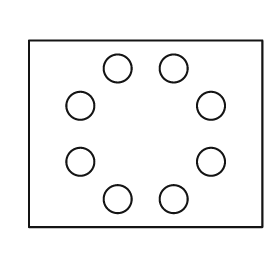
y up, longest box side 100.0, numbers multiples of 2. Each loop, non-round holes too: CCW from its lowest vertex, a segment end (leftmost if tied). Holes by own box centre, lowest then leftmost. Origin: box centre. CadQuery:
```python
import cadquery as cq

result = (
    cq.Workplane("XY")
    .moveTo(-50.0, -40.0)
    .lineTo(50.0, -40.0)
    .lineTo(50.0, 40.0)
    .lineTo(-50.0, 40.0)
    .close()
    .moveTo(-12.0, -28.0)
    .circle(6.0)
    .moveTo(12.0, -28.0)
    .circle(6.0)
    .moveTo(-28.0, -12.0)
    .circle(6.0)
    .moveTo(28.0, -12.0)
    .circle(6.0)
    .moveTo(-28.0, 12.0)
    .circle(6.0)
    .moveTo(28.0, 12.0)
    .circle(6.0)
    .moveTo(-12.0, 28.0)
    .circle(6.0)
    .moveTo(12.0, 28.0)
    .circle(6.0)
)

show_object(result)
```